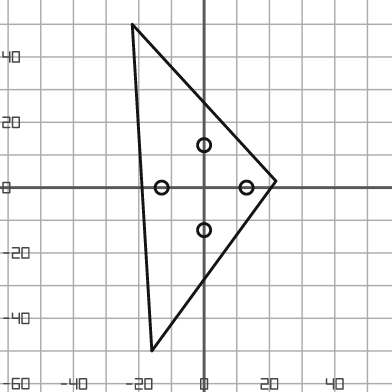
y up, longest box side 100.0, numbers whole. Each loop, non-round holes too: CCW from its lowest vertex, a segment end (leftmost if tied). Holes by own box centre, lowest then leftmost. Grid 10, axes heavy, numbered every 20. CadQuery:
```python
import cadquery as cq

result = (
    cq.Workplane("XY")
    .moveTo(-16.0, -50.0)
    .lineTo(22.0, 2.0)
    .lineTo(-22.0, 50.0)
    .close()
    .moveTo(0.0, -13.0)
    .circle(2.0)
    .moveTo(-13.0, 0.0)
    .circle(2.0)
    .moveTo(13.0, 0.0)
    .circle(2.0)
    .moveTo(0.0, 13.0)
    .circle(2.0)
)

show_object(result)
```